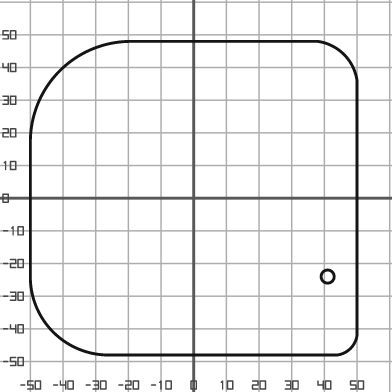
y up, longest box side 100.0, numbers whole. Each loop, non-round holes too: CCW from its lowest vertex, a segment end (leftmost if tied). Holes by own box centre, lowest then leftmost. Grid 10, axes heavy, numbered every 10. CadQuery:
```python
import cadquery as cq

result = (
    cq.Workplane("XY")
    .moveTo(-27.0, -48.0)
    .lineTo(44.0, -48.0)
    .threePointArc((48.0, -46.0), (50.0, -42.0))
    .lineTo(50.0, 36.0)
    .threePointArc((46.0, 44.0), (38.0, 48.0))
    .lineTo(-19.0, 48.0)
    .threePointArc((-41.0, 39.0), (-50.0, 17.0))
    .lineTo(-50.0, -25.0)
    .threePointArc((-43.0, -41.0), (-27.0, -48.0))
    .close()
    .moveTo(41.0, -24.0)
    .circle(2.0)
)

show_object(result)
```